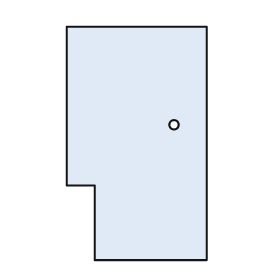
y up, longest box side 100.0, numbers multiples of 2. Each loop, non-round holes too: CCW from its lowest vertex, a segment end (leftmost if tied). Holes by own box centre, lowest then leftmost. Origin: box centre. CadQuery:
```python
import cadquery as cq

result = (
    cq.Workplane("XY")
    .moveTo(-18.0, -50.0)
    .lineTo(30.0, -50.0)
    .lineTo(30.0, 50.0)
    .lineTo(-30.0, 50.0)
    .lineTo(-30.0, -18.0)
    .lineTo(-18.0, -18.0)
    .close()
    .moveTo(16.0, 8.0)
    .circle(2.0)
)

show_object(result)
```